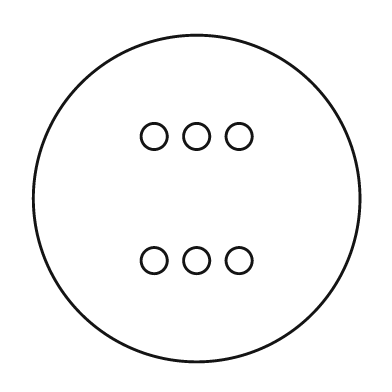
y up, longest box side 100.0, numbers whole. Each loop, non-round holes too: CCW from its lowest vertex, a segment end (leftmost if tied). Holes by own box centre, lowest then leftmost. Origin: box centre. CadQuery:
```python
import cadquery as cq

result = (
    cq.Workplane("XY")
    .moveTo(0.0, 0.0)
    .circle(50.0)
    .moveTo(-13.0, -19.0)
    .circle(4.0)
    .moveTo(0.0, -19.0)
    .circle(4.0)
    .moveTo(13.0, -19.0)
    .circle(4.0)
    .moveTo(-13.0, 19.0)
    .circle(4.0)
    .moveTo(0.0, 19.0)
    .circle(4.0)
    .moveTo(13.0, 19.0)
    .circle(4.0)
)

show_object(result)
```